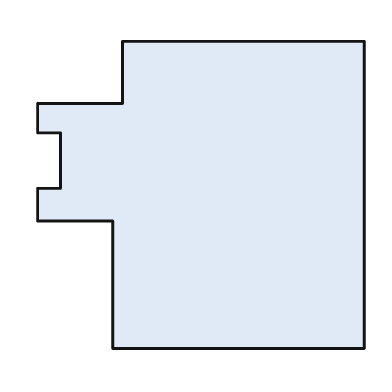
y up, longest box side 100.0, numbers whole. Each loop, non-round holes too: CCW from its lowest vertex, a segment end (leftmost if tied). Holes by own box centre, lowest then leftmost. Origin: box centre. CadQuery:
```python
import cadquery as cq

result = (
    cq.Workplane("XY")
    .moveTo(-27.0, -47.0)
    .lineTo(50.0, -47.0)
    .lineTo(50.0, 47.0)
    .lineTo(-24.0, 47.0)
    .lineTo(-24.0, 28.0)
    .lineTo(-50.0, 28.0)
    .lineTo(-50.0, 19.0)
    .lineTo(-43.0, 19.0)
    .lineTo(-43.0, 2.0)
    .lineTo(-50.0, 2.0)
    .lineTo(-50.0, -8.0)
    .lineTo(-27.0, -8.0)
    .close()
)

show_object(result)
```